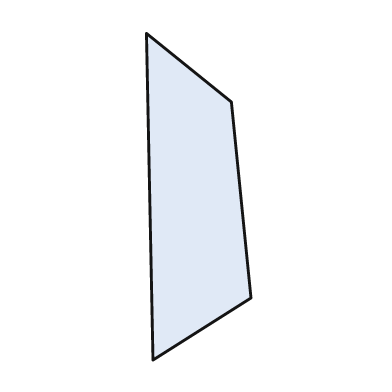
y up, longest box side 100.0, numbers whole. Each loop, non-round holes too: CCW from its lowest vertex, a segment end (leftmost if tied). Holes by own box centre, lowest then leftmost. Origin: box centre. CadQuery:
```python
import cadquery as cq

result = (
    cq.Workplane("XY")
    .moveTo(-14.0, -50.0)
    .lineTo(16.0, -31.0)
    .lineTo(10.0, 29.0)
    .lineTo(-16.0, 50.0)
    .close()
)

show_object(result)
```